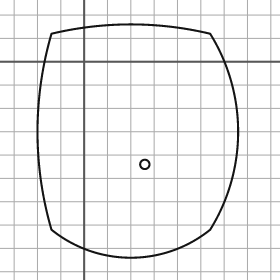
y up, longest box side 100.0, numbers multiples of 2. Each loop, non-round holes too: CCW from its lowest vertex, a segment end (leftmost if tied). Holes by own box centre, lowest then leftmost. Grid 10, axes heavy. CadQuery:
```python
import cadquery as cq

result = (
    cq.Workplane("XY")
    .moveTo(-14.0, -72.0)
    .threePointArc((20.0, -84.0), (54.0, -72.0))
    .threePointArc((66.0, -30.0), (54.0, 12.0))
    .threePointArc((20.0, 16.0), (-14.0, 12.0))
    .threePointArc((-20.0, -30.0), (-14.0, -72.0))
    .close()
    .moveTo(26.0, -44.0)
    .circle(2.0)
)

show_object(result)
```